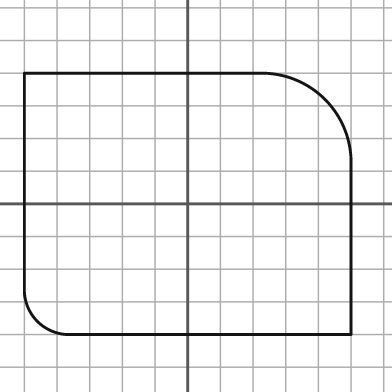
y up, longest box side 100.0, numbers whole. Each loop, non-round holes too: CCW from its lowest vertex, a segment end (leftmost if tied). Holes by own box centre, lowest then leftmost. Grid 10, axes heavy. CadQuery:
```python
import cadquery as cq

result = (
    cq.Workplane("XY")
    .moveTo(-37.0, -40.0)
    .lineTo(50.0, -40.0)
    .lineTo(50.0, 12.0)
    .threePointArc((42.0, 32.0), (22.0, 40.0))
    .lineTo(-50.0, 40.0)
    .lineTo(-50.0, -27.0)
    .threePointArc((-46.0, -36.0), (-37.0, -40.0))
    .close()
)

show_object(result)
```